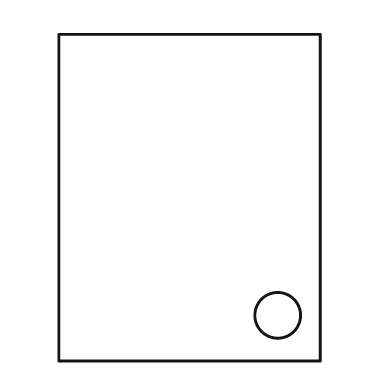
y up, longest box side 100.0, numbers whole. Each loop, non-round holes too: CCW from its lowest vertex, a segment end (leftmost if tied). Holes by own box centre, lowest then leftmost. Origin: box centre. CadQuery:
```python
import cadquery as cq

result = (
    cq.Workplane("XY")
    .moveTo(-40.0, -50.0)
    .lineTo(40.0, -50.0)
    .lineTo(40.0, 50.0)
    .lineTo(-40.0, 50.0)
    .close()
    .moveTo(27.0, -36.0)
    .circle(7.0)
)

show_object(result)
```